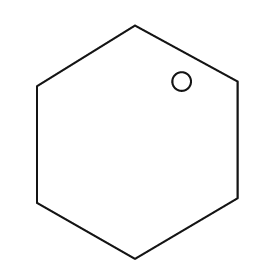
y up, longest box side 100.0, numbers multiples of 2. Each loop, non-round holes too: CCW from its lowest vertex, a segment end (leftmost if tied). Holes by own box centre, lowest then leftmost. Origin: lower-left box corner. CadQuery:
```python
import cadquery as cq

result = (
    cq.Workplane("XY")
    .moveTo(42.0, 0.0)
    .lineTo(86.0, 26.0)
    .lineTo(86.0, 76.0)
    .lineTo(42.0, 100.0)
    .lineTo(0.0, 74.0)
    .lineTo(0.0, 24.0)
    .close()
    .moveTo(62.0, 76.0)
    .circle(4.0)
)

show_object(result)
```